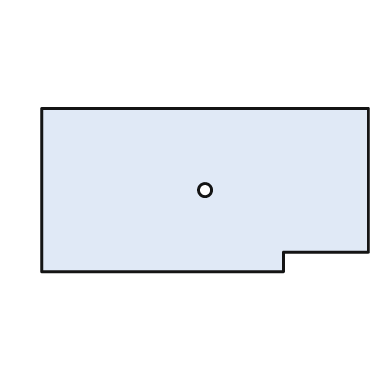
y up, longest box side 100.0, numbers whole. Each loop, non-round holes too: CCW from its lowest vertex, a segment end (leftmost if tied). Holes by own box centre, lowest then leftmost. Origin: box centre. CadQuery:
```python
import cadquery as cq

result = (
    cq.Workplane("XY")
    .moveTo(-50.0, -25.0)
    .lineTo(24.0, -25.0)
    .lineTo(24.0, -19.0)
    .lineTo(50.0, -19.0)
    .lineTo(50.0, 25.0)
    .lineTo(-50.0, 25.0)
    .close()
    .moveTo(0.0, 0.0)
    .circle(2.0)
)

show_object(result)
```